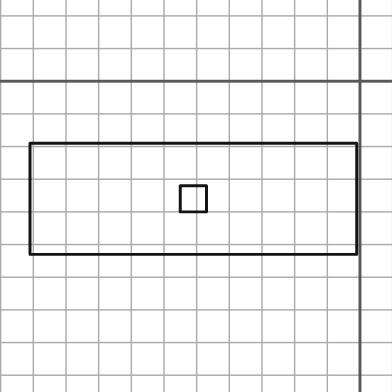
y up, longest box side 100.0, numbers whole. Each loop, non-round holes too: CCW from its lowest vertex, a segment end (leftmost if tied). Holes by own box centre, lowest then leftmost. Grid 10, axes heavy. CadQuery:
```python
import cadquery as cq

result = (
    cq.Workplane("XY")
    .moveTo(-101.0, -53.0)
    .lineTo(-1.0, -53.0)
    .lineTo(-1.0, -19.0)
    .lineTo(-101.0, -19.0)
    .close()
    .moveTo(-55.0, -40.0)
    .lineTo(-47.0, -40.0)
    .lineTo(-47.0, -32.0)
    .lineTo(-55.0, -32.0)
    .close()
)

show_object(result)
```